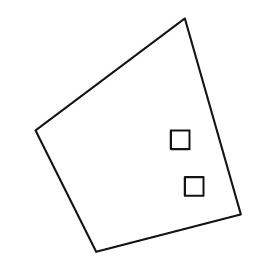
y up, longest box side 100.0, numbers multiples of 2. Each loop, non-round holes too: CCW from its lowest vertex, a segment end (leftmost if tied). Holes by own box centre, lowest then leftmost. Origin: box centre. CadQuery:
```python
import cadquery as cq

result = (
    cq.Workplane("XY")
    .moveTo(-18.0, -50.0)
    .lineTo(44.0, -34.0)
    .lineTo(20.0, 50.0)
    .lineTo(-44.0, 2.0)
    .close()
    .moveTo(20.0, -26.0)
    .lineTo(28.0, -26.0)
    .lineTo(28.0, -18.0)
    .lineTo(20.0, -18.0)
    .close()
    .moveTo(14.0, -6.0)
    .lineTo(22.0, -6.0)
    .lineTo(22.0, 2.0)
    .lineTo(14.0, 2.0)
    .close()
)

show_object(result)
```